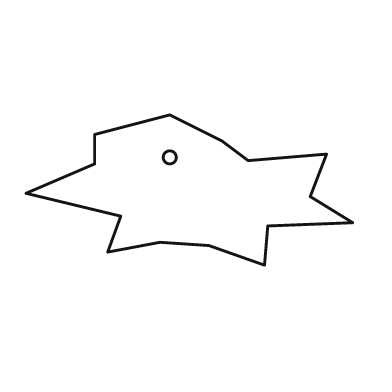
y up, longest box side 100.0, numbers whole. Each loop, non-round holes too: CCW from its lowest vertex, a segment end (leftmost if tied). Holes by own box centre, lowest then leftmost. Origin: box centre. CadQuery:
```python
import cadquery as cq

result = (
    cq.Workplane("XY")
    .moveTo(23.0, -23.0)
    .lineTo(24.0, -11.0)
    .lineTo(50.0, -10.0)
    .lineTo(37.0, -2.0)
    .lineTo(42.0, 11.0)
    .lineTo(18.0, 9.0)
    .lineTo(10.0, 15.0)
    .lineTo(-6.0, 23.0)
    .lineTo(-29.0, 17.0)
    .lineTo(-29.0, 8.0)
    .lineTo(-50.0, -1.0)
    .lineTo(-21.0, -8.0)
    .lineTo(-25.0, -19.0)
    .lineTo(-9.0, -16.0)
    .lineTo(6.0, -17.0)
    .close()
    .moveTo(-6.0, 10.0)
    .circle(2.0)
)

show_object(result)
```